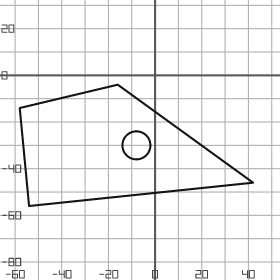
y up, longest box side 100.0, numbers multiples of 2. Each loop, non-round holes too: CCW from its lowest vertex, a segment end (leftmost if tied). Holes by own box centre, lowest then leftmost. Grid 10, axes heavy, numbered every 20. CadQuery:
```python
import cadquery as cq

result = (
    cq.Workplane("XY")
    .moveTo(-54.0, -56.0)
    .lineTo(42.0, -46.0)
    .lineTo(-16.0, -4.0)
    .lineTo(-58.0, -14.0)
    .close()
    .moveTo(-8.0, -30.0)
    .circle(6.0)
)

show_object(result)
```